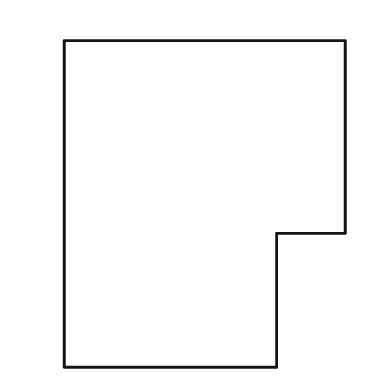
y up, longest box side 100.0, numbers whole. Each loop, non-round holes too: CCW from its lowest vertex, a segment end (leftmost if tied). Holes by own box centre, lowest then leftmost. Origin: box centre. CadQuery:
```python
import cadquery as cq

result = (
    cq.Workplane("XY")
    .moveTo(-43.0, -50.0)
    .lineTo(22.0, -50.0)
    .lineTo(22.0, -9.0)
    .lineTo(43.0, -9.0)
    .lineTo(43.0, 50.0)
    .lineTo(-43.0, 50.0)
    .close()
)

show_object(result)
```